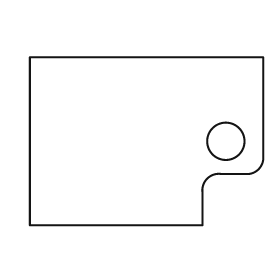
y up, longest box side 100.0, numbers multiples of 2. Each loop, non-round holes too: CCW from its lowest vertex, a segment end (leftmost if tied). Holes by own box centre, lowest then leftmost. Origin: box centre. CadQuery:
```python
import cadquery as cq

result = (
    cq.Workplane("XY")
    .moveTo(-50.0, -36.0)
    .lineTo(24.0, -36.0)
    .lineTo(24.0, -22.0)
    .threePointArc((26.0, -16.0), (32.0, -14.0))
    .lineTo(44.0, -14.0)
    .threePointArc((48.0, -12.0), (50.0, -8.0))
    .lineTo(50.0, 36.0)
    .lineTo(-50.0, 36.0)
    .close()
    .moveTo(34.0, 0.0)
    .circle(8.0)
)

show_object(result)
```